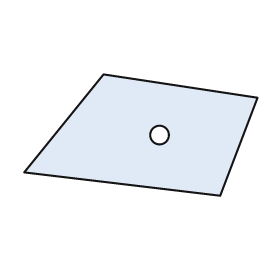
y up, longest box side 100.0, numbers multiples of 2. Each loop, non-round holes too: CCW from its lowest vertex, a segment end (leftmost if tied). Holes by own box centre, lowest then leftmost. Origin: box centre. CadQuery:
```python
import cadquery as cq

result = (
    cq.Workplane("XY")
    .moveTo(34.0, -26.0)
    .lineTo(50.0, 16.0)
    .lineTo(-16.0, 26.0)
    .lineTo(-50.0, -16.0)
    .close()
    .moveTo(8.0, 0.0)
    .circle(4.0)
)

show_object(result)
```